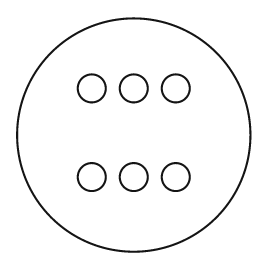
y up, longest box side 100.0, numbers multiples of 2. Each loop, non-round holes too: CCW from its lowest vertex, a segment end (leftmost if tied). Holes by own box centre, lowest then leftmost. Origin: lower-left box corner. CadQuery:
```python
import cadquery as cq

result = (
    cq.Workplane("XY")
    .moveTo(50.0, 50.0)
    .circle(50.0)
    .moveTo(32.0, 32.0)
    .circle(6.0)
    .moveTo(50.0, 32.0)
    .circle(6.0)
    .moveTo(68.0, 32.0)
    .circle(6.0)
    .moveTo(32.0, 70.0)
    .circle(6.0)
    .moveTo(50.0, 70.0)
    .circle(6.0)
    .moveTo(68.0, 70.0)
    .circle(6.0)
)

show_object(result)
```